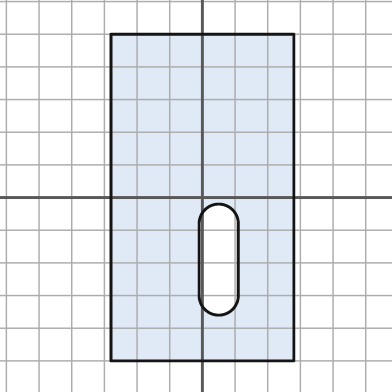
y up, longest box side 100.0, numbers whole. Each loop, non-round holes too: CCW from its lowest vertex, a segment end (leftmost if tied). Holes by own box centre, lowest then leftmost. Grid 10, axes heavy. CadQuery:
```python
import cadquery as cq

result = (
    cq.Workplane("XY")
    .moveTo(-28.0, -50.0)
    .lineTo(28.0, -50.0)
    .lineTo(28.0, 50.0)
    .lineTo(-28.0, 50.0)
    .close()
    .moveTo(-1.0, -30.0)
    .threePointArc((5.0, -36.0), (11.0, -30.0))
    .lineTo(11.0, -8.0)
    .threePointArc((5.0, -2.0), (-1.0, -8.0))
    .close()
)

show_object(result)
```